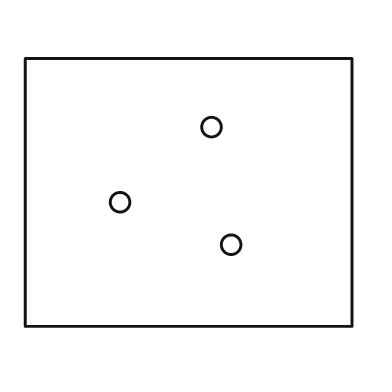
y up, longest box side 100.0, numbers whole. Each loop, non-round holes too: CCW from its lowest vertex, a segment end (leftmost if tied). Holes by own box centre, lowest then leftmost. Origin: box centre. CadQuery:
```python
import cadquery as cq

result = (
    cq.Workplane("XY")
    .moveTo(-50.0, -41.0)
    .lineTo(50.0, -41.0)
    .lineTo(50.0, 41.0)
    .lineTo(-50.0, 41.0)
    .close()
    .moveTo(13.0, -16.0)
    .circle(3.0)
    .moveTo(-21.0, -3.0)
    .circle(3.0)
    .moveTo(7.0, 20.0)
    .circle(3.0)
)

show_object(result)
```